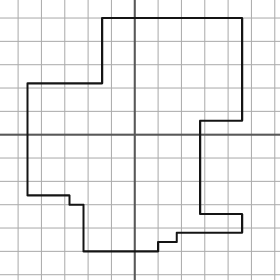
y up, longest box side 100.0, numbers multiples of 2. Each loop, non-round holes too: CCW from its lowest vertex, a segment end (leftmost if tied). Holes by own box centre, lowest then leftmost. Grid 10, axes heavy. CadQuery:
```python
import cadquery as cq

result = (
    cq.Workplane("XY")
    .moveTo(-22.0, -50.0)
    .lineTo(10.0, -50.0)
    .lineTo(10.0, -46.0)
    .lineTo(18.0, -46.0)
    .lineTo(18.0, -42.0)
    .lineTo(46.0, -42.0)
    .lineTo(46.0, -34.0)
    .lineTo(28.0, -34.0)
    .lineTo(28.0, 6.0)
    .lineTo(46.0, 6.0)
    .lineTo(46.0, 50.0)
    .lineTo(-14.0, 50.0)
    .lineTo(-14.0, 22.0)
    .lineTo(-46.0, 22.0)
    .lineTo(-46.0, -26.0)
    .lineTo(-28.0, -26.0)
    .lineTo(-28.0, -30.0)
    .lineTo(-22.0, -30.0)
    .close()
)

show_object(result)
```